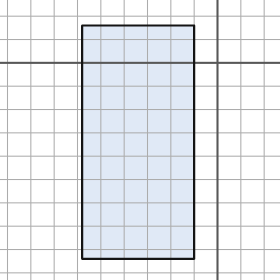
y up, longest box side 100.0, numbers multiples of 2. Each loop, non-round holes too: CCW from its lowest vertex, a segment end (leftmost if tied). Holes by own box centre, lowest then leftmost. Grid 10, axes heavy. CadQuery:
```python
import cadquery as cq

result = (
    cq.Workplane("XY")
    .moveTo(-58.0, -84.0)
    .lineTo(-10.0, -84.0)
    .lineTo(-10.0, 16.0)
    .lineTo(-58.0, 16.0)
    .close()
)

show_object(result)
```